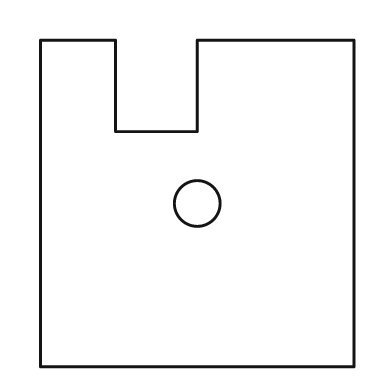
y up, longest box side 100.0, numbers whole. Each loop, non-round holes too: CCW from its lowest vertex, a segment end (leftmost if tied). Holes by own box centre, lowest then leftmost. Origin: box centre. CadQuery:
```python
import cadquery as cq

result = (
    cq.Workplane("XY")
    .moveTo(-48.0, -50.0)
    .lineTo(48.0, -50.0)
    .lineTo(48.0, 50.0)
    .lineTo(0.0, 50.0)
    .lineTo(0.0, 22.0)
    .lineTo(-25.0, 22.0)
    .lineTo(-25.0, 50.0)
    .lineTo(-48.0, 50.0)
    .close()
    .moveTo(0.0, 0.0)
    .circle(7.0)
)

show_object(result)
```